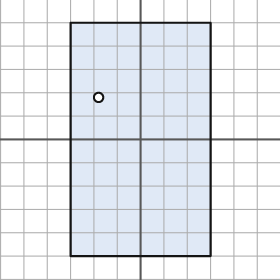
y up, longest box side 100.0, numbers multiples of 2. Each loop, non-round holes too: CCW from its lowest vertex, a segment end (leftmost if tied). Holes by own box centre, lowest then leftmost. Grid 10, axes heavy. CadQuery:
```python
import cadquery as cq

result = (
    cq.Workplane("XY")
    .moveTo(-30.0, -50.0)
    .lineTo(30.0, -50.0)
    .lineTo(30.0, 50.0)
    .lineTo(-30.0, 50.0)
    .close()
    .moveTo(-18.0, 18.0)
    .circle(2.0)
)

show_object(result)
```